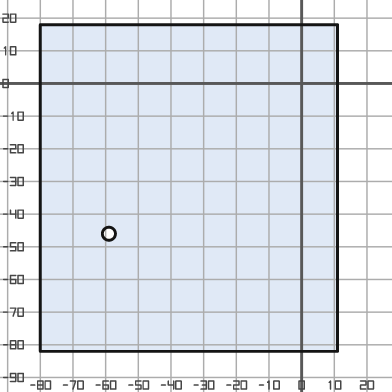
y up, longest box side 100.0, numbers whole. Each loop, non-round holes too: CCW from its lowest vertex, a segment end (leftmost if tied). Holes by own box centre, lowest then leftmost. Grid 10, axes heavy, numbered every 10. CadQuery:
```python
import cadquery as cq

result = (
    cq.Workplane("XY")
    .moveTo(-80.0, -82.0)
    .lineTo(11.0, -82.0)
    .lineTo(11.0, 18.0)
    .lineTo(-80.0, 18.0)
    .close()
    .moveTo(-59.0, -46.0)
    .circle(2.0)
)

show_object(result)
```